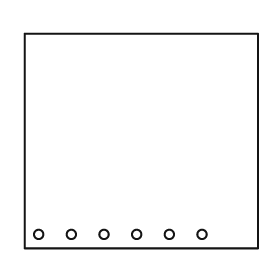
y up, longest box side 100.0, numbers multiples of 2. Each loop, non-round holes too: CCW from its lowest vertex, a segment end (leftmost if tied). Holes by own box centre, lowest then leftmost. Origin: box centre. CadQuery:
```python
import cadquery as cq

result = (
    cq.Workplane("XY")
    .moveTo(-50.0, -46.0)
    .lineTo(50.0, -46.0)
    .lineTo(50.0, 46.0)
    .lineTo(-50.0, 46.0)
    .close()
    .moveTo(-44.0, -40.0)
    .circle(2.0)
    .moveTo(-30.0, -40.0)
    .circle(2.0)
    .moveTo(-16.0, -40.0)
    .circle(2.0)
    .moveTo(-2.0, -40.0)
    .circle(2.0)
    .moveTo(12.0, -40.0)
    .circle(2.0)
    .moveTo(26.0, -40.0)
    .circle(2.0)
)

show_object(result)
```